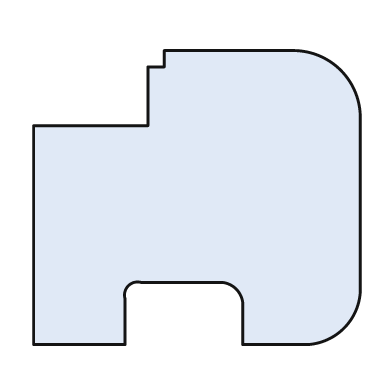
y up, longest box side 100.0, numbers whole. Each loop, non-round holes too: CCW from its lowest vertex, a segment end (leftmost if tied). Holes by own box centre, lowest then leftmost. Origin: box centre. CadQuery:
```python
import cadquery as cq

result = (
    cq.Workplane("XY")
    .moveTo(-50.0, -45.0)
    .lineTo(-22.0, -45.0)
    .lineTo(-22.0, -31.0)
    .threePointArc((-21.0, -27.0), (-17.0, -26.0))
    .lineTo(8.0, -26.0)
    .threePointArc((12.0, -28.0), (14.0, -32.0))
    .lineTo(14.0, -45.0)
    .lineTo(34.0, -45.0)
    .threePointArc((45.0, -40.0), (50.0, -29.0))
    .lineTo(50.0, 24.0)
    .threePointArc((44.0, 39.0), (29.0, 45.0))
    .lineTo(-10.0, 45.0)
    .lineTo(-10.0, 40.0)
    .lineTo(-15.0, 40.0)
    .lineTo(-15.0, 22.0)
    .lineTo(-50.0, 22.0)
    .close()
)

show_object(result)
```